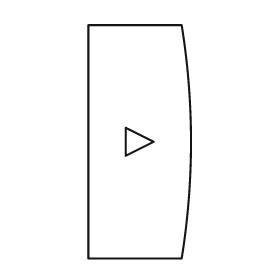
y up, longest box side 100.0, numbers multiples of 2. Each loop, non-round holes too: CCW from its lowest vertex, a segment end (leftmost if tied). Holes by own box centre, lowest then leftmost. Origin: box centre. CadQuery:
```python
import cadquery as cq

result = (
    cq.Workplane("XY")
    .moveTo(-22.0, -50.0)
    .lineTo(18.0, -50.0)
    .threePointArc((22.0, 0.0), (18.0, 50.0))
    .lineTo(-22.0, 50.0)
    .close()
    .moveTo(-6.0, -6.0)
    .lineTo(6.0, 0.0)
    .lineTo(-6.0, 6.0)
    .close()
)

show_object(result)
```